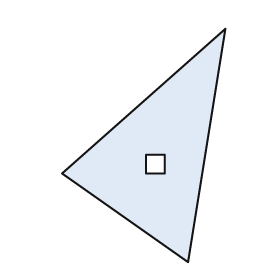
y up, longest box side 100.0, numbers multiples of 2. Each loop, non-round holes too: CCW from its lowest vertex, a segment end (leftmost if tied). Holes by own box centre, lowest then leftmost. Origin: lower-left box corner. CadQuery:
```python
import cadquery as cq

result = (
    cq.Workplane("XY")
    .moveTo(54.0, 0.0)
    .lineTo(70.0, 100.0)
    .lineTo(0.0, 38.0)
    .close()
    .moveTo(36.0, 38.0)
    .lineTo(44.0, 38.0)
    .lineTo(44.0, 46.0)
    .lineTo(36.0, 46.0)
    .close()
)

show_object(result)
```